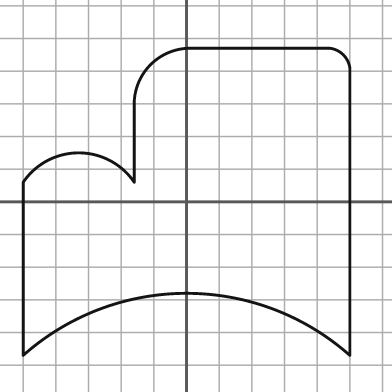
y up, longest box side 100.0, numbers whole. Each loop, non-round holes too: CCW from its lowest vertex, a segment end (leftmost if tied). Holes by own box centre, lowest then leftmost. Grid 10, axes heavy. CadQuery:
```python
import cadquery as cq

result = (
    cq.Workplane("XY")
    .moveTo(-50.0, -47.0)
    .threePointArc((0.0, -28.0), (50.0, -47.0))
    .lineTo(50.0, 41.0)
    .threePointArc((48.0, 45.0), (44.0, 47.0))
    .lineTo(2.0, 47.0)
    .threePointArc((-11.0, 42.0), (-16.0, 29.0))
    .lineTo(-16.0, 6.0)
    .threePointArc((-33.0, 15.0), (-50.0, 6.0))
    .close()
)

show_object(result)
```